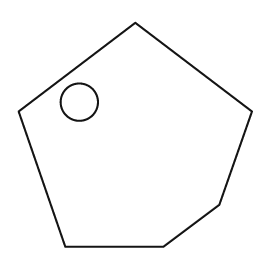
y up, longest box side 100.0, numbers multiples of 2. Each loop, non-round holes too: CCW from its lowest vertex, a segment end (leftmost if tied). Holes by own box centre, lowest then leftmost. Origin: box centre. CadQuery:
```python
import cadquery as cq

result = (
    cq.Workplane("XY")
    .moveTo(-30.0, -48.0)
    .lineTo(12.0, -48.0)
    .lineTo(36.0, -30.0)
    .lineTo(50.0, 10.0)
    .lineTo(0.0, 48.0)
    .lineTo(-50.0, 10.0)
    .close()
    .moveTo(-24.0, 14.0)
    .circle(8.0)
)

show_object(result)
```